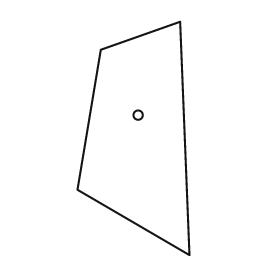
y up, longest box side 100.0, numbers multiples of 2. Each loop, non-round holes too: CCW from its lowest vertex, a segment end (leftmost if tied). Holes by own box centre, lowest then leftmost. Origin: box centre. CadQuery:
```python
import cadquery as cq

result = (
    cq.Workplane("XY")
    .moveTo(24.0, -50.0)
    .lineTo(20.0, 50.0)
    .lineTo(-14.0, 38.0)
    .lineTo(-24.0, -22.0)
    .close()
    .moveTo(2.0, 10.0)
    .circle(2.0)
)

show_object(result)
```